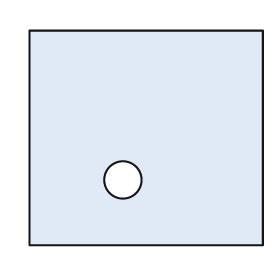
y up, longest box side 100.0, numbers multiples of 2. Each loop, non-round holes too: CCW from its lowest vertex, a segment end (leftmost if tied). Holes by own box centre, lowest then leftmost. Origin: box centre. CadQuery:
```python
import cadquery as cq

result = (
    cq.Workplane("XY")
    .moveTo(-50.0, -46.0)
    .lineTo(50.0, -46.0)
    .lineTo(50.0, 46.0)
    .lineTo(-50.0, 46.0)
    .close()
    .moveTo(-10.0, -18.0)
    .circle(8.0)
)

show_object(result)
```